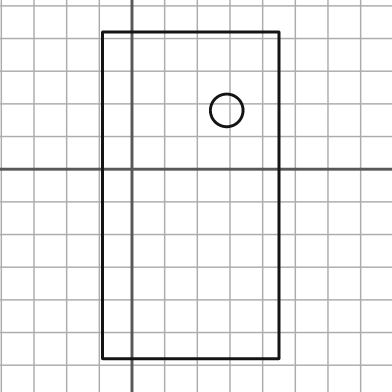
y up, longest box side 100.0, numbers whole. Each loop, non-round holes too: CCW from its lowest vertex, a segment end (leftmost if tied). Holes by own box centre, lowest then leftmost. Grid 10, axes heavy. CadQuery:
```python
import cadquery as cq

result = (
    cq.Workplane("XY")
    .moveTo(-9.0, -58.0)
    .lineTo(45.0, -58.0)
    .lineTo(45.0, 42.0)
    .lineTo(-9.0, 42.0)
    .close()
    .moveTo(29.0, 18.0)
    .circle(5.0)
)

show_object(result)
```